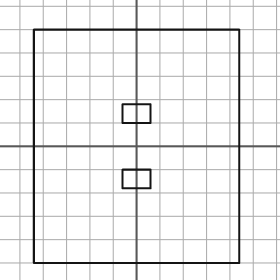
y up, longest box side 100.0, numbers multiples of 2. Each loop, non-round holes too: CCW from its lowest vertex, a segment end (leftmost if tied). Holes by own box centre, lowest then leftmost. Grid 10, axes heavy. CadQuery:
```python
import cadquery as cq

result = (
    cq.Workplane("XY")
    .moveTo(-44.0, -50.0)
    .lineTo(44.0, -50.0)
    .lineTo(44.0, 50.0)
    .lineTo(-44.0, 50.0)
    .close()
    .moveTo(-6.0, -18.0)
    .lineTo(6.0, -18.0)
    .lineTo(6.0, -10.0)
    .lineTo(-6.0, -10.0)
    .close()
    .moveTo(-6.0, 10.0)
    .lineTo(6.0, 10.0)
    .lineTo(6.0, 18.0)
    .lineTo(-6.0, 18.0)
    .close()
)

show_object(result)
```